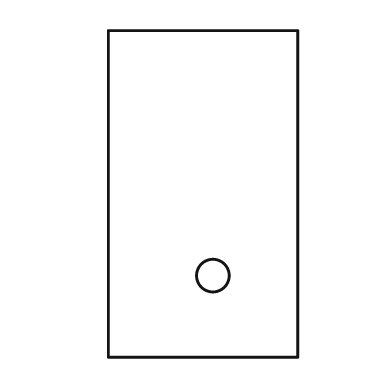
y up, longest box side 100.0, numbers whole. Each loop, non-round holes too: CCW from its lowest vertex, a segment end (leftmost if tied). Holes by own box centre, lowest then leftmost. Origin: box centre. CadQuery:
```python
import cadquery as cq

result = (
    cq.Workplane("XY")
    .moveTo(-29.0, -50.0)
    .lineTo(29.0, -50.0)
    .lineTo(29.0, 50.0)
    .lineTo(-29.0, 50.0)
    .close()
    .moveTo(3.0, -25.0)
    .circle(5.0)
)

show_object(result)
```